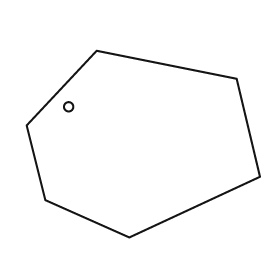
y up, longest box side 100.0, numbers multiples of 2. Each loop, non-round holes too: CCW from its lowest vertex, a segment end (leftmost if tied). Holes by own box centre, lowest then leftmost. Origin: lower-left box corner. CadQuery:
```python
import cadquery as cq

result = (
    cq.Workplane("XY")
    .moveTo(44.0, 0.0)
    .lineTo(100.0, 26.0)
    .lineTo(90.0, 68.0)
    .lineTo(30.0, 80.0)
    .lineTo(0.0, 48.0)
    .lineTo(8.0, 16.0)
    .close()
    .moveTo(18.0, 56.0)
    .circle(2.0)
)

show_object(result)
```